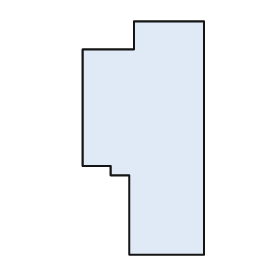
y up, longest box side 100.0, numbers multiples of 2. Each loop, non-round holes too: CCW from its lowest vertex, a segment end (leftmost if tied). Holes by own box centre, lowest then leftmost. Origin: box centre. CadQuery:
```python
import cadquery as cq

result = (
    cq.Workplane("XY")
    .moveTo(-6.0, -50.0)
    .lineTo(26.0, -50.0)
    .lineTo(26.0, 50.0)
    .lineTo(-4.0, 50.0)
    .lineTo(-4.0, 38.0)
    .lineTo(-26.0, 38.0)
    .lineTo(-26.0, -12.0)
    .lineTo(-14.0, -12.0)
    .lineTo(-14.0, -16.0)
    .lineTo(-6.0, -16.0)
    .close()
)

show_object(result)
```